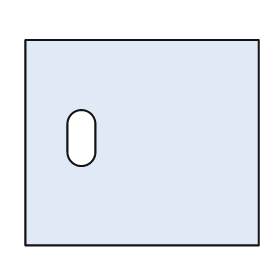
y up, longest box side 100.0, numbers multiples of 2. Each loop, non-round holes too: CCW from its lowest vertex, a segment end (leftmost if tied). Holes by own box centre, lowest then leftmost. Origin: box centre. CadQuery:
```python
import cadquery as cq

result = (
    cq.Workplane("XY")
    .moveTo(-50.0, -44.0)
    .lineTo(50.0, -44.0)
    .lineTo(50.0, 44.0)
    .lineTo(-50.0, 44.0)
    .close()
    .moveTo(-32.0, -4.0)
    .threePointArc((-26.0, -10.0), (-20.0, -4.0))
    .lineTo(-20.0, 8.0)
    .threePointArc((-26.0, 14.0), (-32.0, 8.0))
    .close()
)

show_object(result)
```